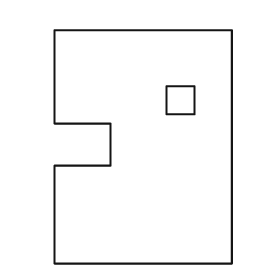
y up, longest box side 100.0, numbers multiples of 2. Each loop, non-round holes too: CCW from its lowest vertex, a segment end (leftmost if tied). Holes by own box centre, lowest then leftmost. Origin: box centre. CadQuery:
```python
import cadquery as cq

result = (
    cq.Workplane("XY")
    .moveTo(-38.0, -50.0)
    .lineTo(38.0, -50.0)
    .lineTo(38.0, 50.0)
    .lineTo(-38.0, 50.0)
    .lineTo(-38.0, 10.0)
    .lineTo(-14.0, 10.0)
    .lineTo(-14.0, -8.0)
    .lineTo(-38.0, -8.0)
    .close()
    .moveTo(10.0, 14.0)
    .lineTo(22.0, 14.0)
    .lineTo(22.0, 26.0)
    .lineTo(10.0, 26.0)
    .close()
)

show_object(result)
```